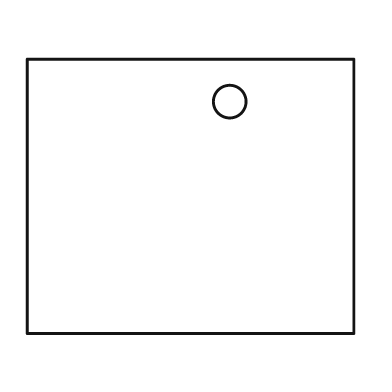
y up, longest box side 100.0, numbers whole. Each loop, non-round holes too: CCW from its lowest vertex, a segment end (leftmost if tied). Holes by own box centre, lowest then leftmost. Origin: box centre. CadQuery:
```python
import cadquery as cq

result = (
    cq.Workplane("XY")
    .moveTo(-50.0, -42.0)
    .lineTo(50.0, -42.0)
    .lineTo(50.0, 42.0)
    .lineTo(-50.0, 42.0)
    .close()
    .moveTo(12.0, 29.0)
    .circle(5.0)
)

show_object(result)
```